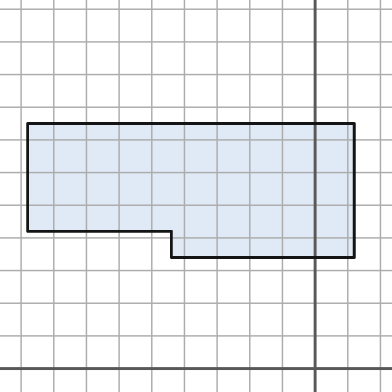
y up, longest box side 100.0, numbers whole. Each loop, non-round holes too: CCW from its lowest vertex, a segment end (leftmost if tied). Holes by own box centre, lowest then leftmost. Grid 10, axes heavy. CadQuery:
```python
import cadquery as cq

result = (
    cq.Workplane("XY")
    .moveTo(-44.0, 34.0)
    .lineTo(12.0, 34.0)
    .lineTo(12.0, 75.0)
    .lineTo(-88.0, 75.0)
    .lineTo(-88.0, 42.0)
    .lineTo(-44.0, 42.0)
    .close()
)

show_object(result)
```